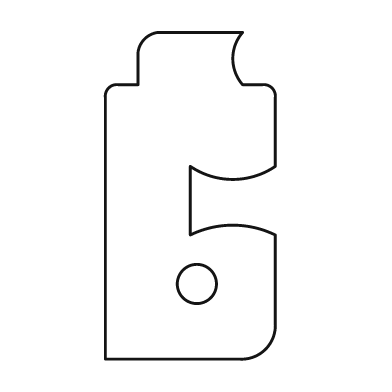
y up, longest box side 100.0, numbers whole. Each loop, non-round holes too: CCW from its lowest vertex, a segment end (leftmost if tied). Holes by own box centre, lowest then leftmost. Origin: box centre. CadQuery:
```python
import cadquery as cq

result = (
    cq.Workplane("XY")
    .moveTo(-26.0, -50.0)
    .lineTo(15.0, -50.0)
    .threePointArc((23.0, -47.0), (26.0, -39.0))
    .lineTo(26.0, -12.0)
    .threePointArc((13.0, -9.0), (0.0, -12.0))
    .lineTo(0.0, 9.0)
    .threePointArc((13.0, 5.0), (26.0, 9.0))
    .lineTo(26.0, 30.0)
    .threePointArc((25.0, 33.0), (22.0, 34.0))
    .lineTo(16.0, 34.0)
    .threePointArc((13.0, 42.0), (16.0, 50.0))
    .lineTo(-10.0, 50.0)
    .threePointArc((-14.0, 48.0), (-16.0, 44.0))
    .lineTo(-16.0, 34.0)
    .lineTo(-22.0, 34.0)
    .threePointArc((-25.0, 33.0), (-26.0, 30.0))
    .close()
    .moveTo(2.0, -27.0)
    .circle(6.0)
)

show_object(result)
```